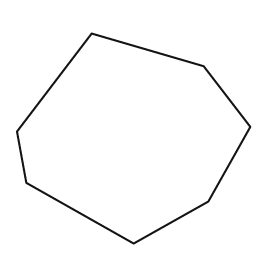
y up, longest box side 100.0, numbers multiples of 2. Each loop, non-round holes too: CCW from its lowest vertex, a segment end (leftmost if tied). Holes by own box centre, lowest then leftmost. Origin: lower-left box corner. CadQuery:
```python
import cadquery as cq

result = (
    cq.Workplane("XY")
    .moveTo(50.0, 0.0)
    .lineTo(82.0, 18.0)
    .lineTo(100.0, 50.0)
    .lineTo(80.0, 76.0)
    .lineTo(32.0, 90.0)
    .lineTo(0.0, 48.0)
    .lineTo(4.0, 26.0)
    .close()
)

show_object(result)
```